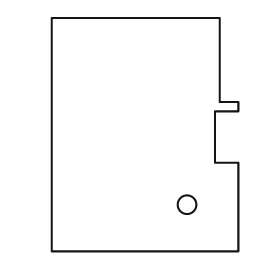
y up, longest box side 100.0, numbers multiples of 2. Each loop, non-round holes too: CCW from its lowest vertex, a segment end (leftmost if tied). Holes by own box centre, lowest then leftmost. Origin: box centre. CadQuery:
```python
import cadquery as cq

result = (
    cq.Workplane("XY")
    .moveTo(-40.0, -50.0)
    .lineTo(40.0, -50.0)
    .lineTo(40.0, -12.0)
    .lineTo(30.0, -12.0)
    .lineTo(30.0, 10.0)
    .lineTo(40.0, 10.0)
    .lineTo(40.0, 14.0)
    .lineTo(32.0, 14.0)
    .lineTo(32.0, 50.0)
    .lineTo(-40.0, 50.0)
    .close()
    .moveTo(18.0, -30.0)
    .circle(4.0)
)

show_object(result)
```